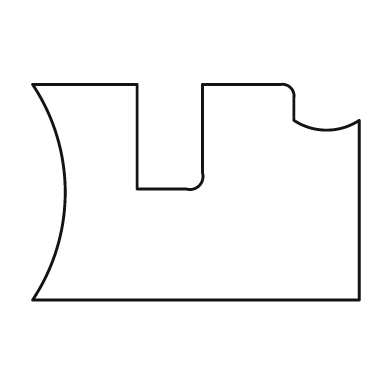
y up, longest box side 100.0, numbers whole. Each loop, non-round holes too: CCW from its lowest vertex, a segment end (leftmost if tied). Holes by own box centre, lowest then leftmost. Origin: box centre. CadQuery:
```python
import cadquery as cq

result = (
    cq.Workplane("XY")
    .moveTo(-50.0, -33.0)
    .lineTo(50.0, -33.0)
    .lineTo(50.0, 22.0)
    .threePointArc((40.0, 19.0), (30.0, 22.0))
    .lineTo(30.0, 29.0)
    .threePointArc((29.0, 32.0), (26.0, 33.0))
    .lineTo(2.0, 33.0)
    .lineTo(2.0, 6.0)
    .threePointArc((1.0, 2.0), (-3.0, 1.0))
    .lineTo(-18.0, 1.0)
    .lineTo(-18.0, 33.0)
    .lineTo(-50.0, 33.0)
    .threePointArc((-40.0, 0.0), (-50.0, -33.0))
    .close()
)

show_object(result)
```